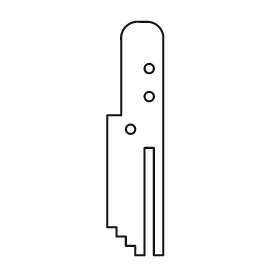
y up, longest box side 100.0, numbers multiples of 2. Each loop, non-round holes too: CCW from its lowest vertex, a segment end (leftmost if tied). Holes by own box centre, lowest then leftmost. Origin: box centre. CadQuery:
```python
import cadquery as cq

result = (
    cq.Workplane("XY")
    .moveTo(0.0, -50.0)
    .lineTo(4.0, -50.0)
    .lineTo(4.0, -4.0)
    .lineTo(8.0, -4.0)
    .lineTo(8.0, -50.0)
    .lineTo(12.0, -50.0)
    .lineTo(12.0, 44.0)
    .threePointArc((10.0, 48.0), (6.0, 50.0))
    .lineTo(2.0, 50.0)
    .threePointArc((-4.0, 48.0), (-6.0, 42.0))
    .lineTo(-6.0, 10.0)
    .lineTo(-12.0, 10.0)
    .lineTo(-12.0, -38.0)
    .lineTo(-8.0, -38.0)
    .lineTo(-8.0, -42.0)
    .lineTo(-4.0, -42.0)
    .lineTo(-4.0, -46.0)
    .lineTo(0.0, -46.0)
    .close()
    .moveTo(-2.0, 4.0)
    .circle(2.0)
    .moveTo(6.0, 18.0)
    .circle(2.0)
    .moveTo(6.0, 30.0)
    .circle(2.0)
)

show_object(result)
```